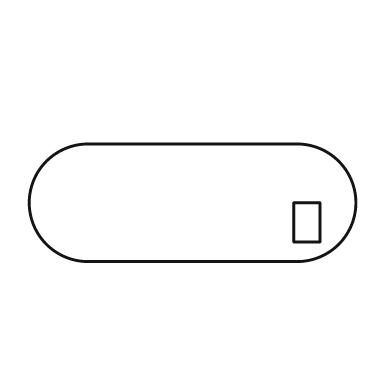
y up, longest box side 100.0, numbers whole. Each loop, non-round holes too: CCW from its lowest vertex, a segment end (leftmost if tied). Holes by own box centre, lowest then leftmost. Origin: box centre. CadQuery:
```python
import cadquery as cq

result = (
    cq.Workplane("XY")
    .moveTo(-32.0, -18.0)
    .lineTo(32.0, -18.0)
    .threePointArc((50.0, 0.0), (32.0, 18.0))
    .lineTo(-32.0, 18.0)
    .threePointArc((-50.0, 0.0), (-32.0, -18.0))
    .close()
    .moveTo(31.0, -12.0)
    .lineTo(39.0, -12.0)
    .lineTo(39.0, 0.0)
    .lineTo(31.0, 0.0)
    .close()
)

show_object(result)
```